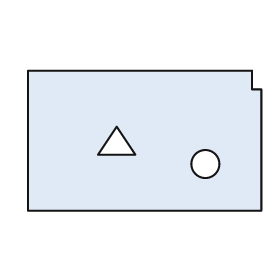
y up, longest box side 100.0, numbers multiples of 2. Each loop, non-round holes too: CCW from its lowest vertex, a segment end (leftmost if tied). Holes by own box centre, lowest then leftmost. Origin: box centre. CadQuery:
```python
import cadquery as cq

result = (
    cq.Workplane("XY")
    .moveTo(-50.0, -30.0)
    .lineTo(50.0, -30.0)
    .lineTo(50.0, 22.0)
    .lineTo(46.0, 22.0)
    .lineTo(46.0, 30.0)
    .lineTo(-50.0, 30.0)
    .close()
    .moveTo(26.0, -10.0)
    .circle(6.0)
    .moveTo(-20.0, -6.0)
    .lineTo(-4.0, -6.0)
    .lineTo(-12.0, 6.0)
    .close()
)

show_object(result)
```